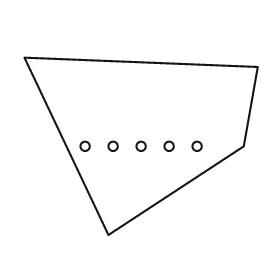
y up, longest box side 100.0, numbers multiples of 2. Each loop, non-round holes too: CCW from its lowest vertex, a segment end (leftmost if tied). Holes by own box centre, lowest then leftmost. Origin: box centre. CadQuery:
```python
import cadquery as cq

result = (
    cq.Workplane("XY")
    .moveTo(-14.0, -38.0)
    .lineTo(44.0, 0.0)
    .lineTo(50.0, 34.0)
    .lineTo(-50.0, 38.0)
    .close()
    .moveTo(-24.0, 0.0)
    .circle(2.0)
    .moveTo(-12.0, 0.0)
    .circle(2.0)
    .moveTo(0.0, 0.0)
    .circle(2.0)
    .moveTo(12.0, 0.0)
    .circle(2.0)
    .moveTo(24.0, 0.0)
    .circle(2.0)
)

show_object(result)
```